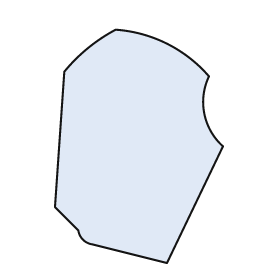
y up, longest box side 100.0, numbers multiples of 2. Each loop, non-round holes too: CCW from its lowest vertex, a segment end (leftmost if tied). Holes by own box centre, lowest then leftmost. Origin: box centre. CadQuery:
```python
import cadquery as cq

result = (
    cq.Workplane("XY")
    .moveTo(12.0, -50.0)
    .lineTo(36.0, 0.0)
    .threePointArc((28.0, 14.0), (30.0, 30.0))
    .threePointArc((12.0, 44.0), (-10.0, 50.0))
    .threePointArc((-22.0, 42.0), (-32.0, 32.0))
    .lineTo(-36.0, -26.0)
    .lineTo(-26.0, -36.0)
    .threePointArc((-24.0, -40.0), (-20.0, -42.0))
    .close()
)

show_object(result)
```